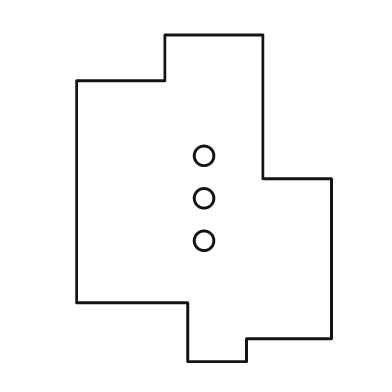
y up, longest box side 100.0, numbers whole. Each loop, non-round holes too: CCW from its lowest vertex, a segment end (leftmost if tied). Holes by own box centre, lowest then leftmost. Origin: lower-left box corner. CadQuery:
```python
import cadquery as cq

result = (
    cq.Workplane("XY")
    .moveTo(34.0, 0.0)
    .lineTo(52.0, 0.0)
    .lineTo(52.0, 7.0)
    .lineTo(78.0, 7.0)
    .lineTo(78.0, 56.0)
    .lineTo(57.0, 56.0)
    .lineTo(57.0, 100.0)
    .lineTo(27.0, 100.0)
    .lineTo(27.0, 86.0)
    .lineTo(0.0, 86.0)
    .lineTo(0.0, 18.0)
    .lineTo(34.0, 18.0)
    .close()
    .moveTo(39.0, 37.0)
    .circle(3.0)
    .moveTo(39.0, 50.0)
    .circle(3.0)
    .moveTo(39.0, 63.0)
    .circle(3.0)
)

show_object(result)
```